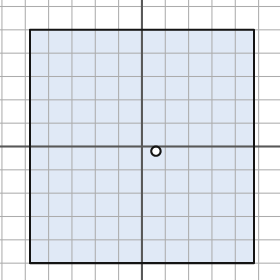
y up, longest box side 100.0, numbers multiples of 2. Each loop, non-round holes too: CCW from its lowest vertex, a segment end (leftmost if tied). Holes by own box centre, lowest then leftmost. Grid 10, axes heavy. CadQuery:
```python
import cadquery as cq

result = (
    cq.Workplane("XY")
    .moveTo(-48.0, -50.0)
    .lineTo(48.0, -50.0)
    .lineTo(48.0, 50.0)
    .lineTo(-48.0, 50.0)
    .close()
    .moveTo(6.0, -2.0)
    .circle(2.0)
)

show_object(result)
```